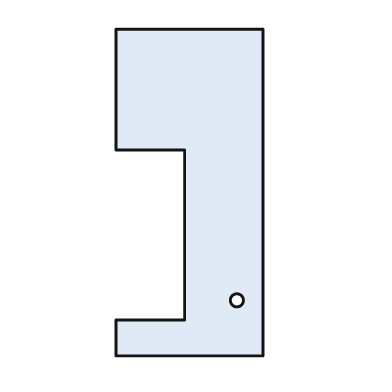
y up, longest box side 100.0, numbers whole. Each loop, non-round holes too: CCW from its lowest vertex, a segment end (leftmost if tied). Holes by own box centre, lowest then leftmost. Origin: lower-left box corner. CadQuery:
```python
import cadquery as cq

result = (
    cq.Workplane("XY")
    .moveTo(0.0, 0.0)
    .lineTo(45.0, 0.0)
    .lineTo(45.0, 100.0)
    .lineTo(0.0, 100.0)
    .lineTo(0.0, 63.0)
    .lineTo(21.0, 63.0)
    .lineTo(21.0, 11.0)
    .lineTo(0.0, 11.0)
    .close()
    .moveTo(37.0, 17.0)
    .circle(2.0)
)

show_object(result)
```